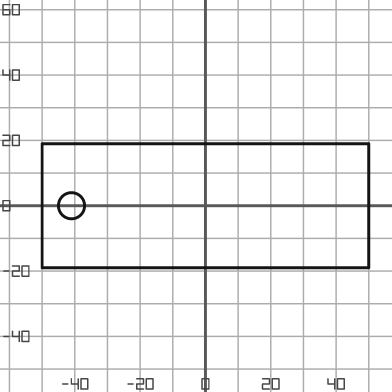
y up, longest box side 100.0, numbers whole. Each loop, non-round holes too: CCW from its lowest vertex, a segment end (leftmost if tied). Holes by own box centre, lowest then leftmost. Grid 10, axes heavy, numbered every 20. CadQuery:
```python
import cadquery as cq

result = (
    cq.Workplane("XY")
    .moveTo(-50.0, -19.0)
    .lineTo(50.0, -19.0)
    .lineTo(50.0, 19.0)
    .lineTo(-50.0, 19.0)
    .close()
    .moveTo(-41.0, 0.0)
    .circle(4.0)
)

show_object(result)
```